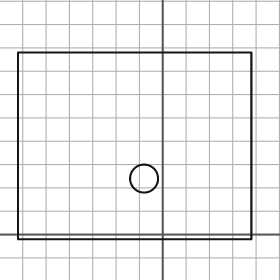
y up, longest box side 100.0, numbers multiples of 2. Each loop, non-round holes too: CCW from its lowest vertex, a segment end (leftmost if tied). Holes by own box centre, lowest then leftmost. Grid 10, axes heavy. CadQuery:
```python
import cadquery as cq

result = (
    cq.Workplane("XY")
    .moveTo(-62.0, -2.0)
    .lineTo(38.0, -2.0)
    .lineTo(38.0, 78.0)
    .lineTo(-62.0, 78.0)
    .close()
    .moveTo(-8.0, 24.0)
    .circle(6.0)
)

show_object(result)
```